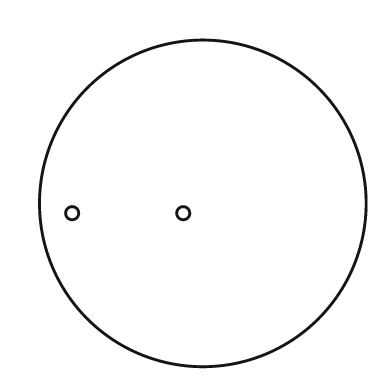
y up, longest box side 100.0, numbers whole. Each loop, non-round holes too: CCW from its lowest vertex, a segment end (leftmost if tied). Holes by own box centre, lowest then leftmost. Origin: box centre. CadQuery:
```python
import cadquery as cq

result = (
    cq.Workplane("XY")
    .moveTo(0.0, 0.0)
    .circle(50.0)
    .moveTo(-40.0, -3.0)
    .circle(2.0)
    .moveTo(-6.0, -3.0)
    .circle(2.0)
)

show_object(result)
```